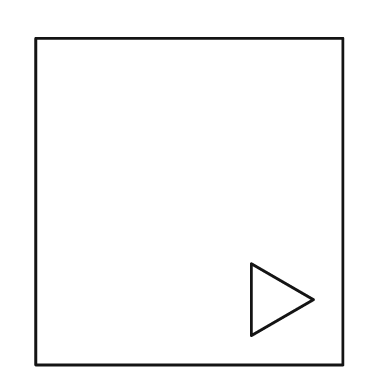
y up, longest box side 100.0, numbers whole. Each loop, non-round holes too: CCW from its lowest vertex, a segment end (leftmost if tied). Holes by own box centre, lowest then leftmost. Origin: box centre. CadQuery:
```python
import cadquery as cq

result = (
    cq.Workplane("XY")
    .moveTo(-47.0, -50.0)
    .lineTo(47.0, -50.0)
    .lineTo(47.0, 50.0)
    .lineTo(-47.0, 50.0)
    .close()
    .moveTo(19.0, -41.0)
    .lineTo(38.0, -30.0)
    .lineTo(19.0, -19.0)
    .close()
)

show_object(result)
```